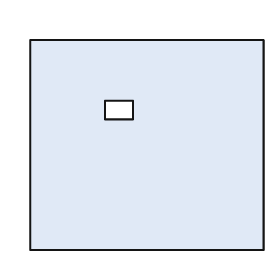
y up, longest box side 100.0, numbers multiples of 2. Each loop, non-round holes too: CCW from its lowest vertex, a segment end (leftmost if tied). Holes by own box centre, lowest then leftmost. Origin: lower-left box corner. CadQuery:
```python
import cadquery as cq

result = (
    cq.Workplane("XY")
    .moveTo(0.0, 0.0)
    .lineTo(100.0, 0.0)
    .lineTo(100.0, 90.0)
    .lineTo(0.0, 90.0)
    .close()
    .moveTo(32.0, 56.0)
    .lineTo(44.0, 56.0)
    .lineTo(44.0, 64.0)
    .lineTo(32.0, 64.0)
    .close()
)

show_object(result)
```